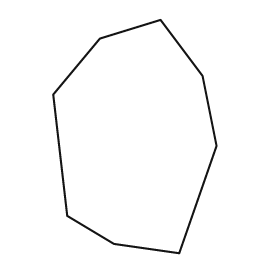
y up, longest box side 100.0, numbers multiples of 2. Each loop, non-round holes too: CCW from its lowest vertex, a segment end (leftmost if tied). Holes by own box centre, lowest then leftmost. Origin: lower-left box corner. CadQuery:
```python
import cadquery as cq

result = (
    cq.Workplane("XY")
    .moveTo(54.0, 0.0)
    .lineTo(70.0, 46.0)
    .lineTo(64.0, 76.0)
    .lineTo(46.0, 100.0)
    .lineTo(20.0, 92.0)
    .lineTo(0.0, 68.0)
    .lineTo(6.0, 16.0)
    .lineTo(26.0, 4.0)
    .close()
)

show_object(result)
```